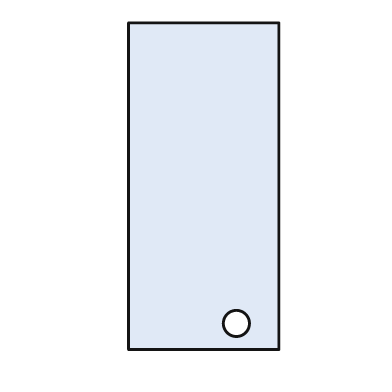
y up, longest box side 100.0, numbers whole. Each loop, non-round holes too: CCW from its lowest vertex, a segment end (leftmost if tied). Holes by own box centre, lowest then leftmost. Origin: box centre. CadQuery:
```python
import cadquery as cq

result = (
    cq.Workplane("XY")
    .moveTo(-23.0, -50.0)
    .lineTo(23.0, -50.0)
    .lineTo(23.0, 50.0)
    .lineTo(-23.0, 50.0)
    .close()
    .moveTo(10.0, -42.0)
    .circle(4.0)
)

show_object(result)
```